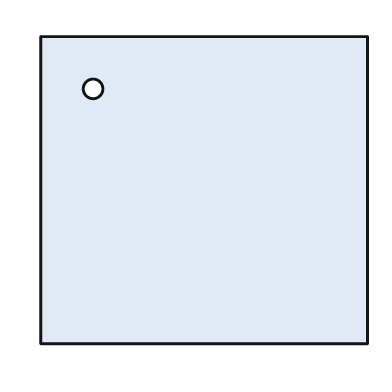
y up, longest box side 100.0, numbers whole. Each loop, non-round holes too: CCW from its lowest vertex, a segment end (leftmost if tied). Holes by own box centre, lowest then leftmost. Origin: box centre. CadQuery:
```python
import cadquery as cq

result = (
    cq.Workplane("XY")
    .moveTo(-50.0, -47.0)
    .lineTo(50.0, -47.0)
    .lineTo(50.0, 47.0)
    .lineTo(-50.0, 47.0)
    .close()
    .moveTo(-34.0, 31.0)
    .circle(3.0)
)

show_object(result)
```